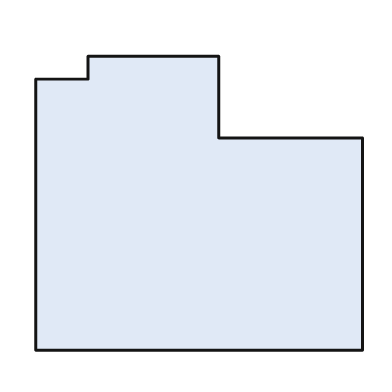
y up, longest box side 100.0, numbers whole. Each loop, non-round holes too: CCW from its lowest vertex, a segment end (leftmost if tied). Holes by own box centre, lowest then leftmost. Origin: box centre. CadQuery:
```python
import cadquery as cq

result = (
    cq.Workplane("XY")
    .moveTo(-50.0, -45.0)
    .lineTo(50.0, -45.0)
    .lineTo(50.0, 20.0)
    .lineTo(6.0, 20.0)
    .lineTo(6.0, 45.0)
    .lineTo(-34.0, 45.0)
    .lineTo(-34.0, 38.0)
    .lineTo(-50.0, 38.0)
    .close()
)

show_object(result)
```